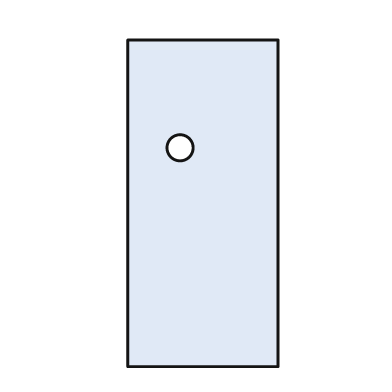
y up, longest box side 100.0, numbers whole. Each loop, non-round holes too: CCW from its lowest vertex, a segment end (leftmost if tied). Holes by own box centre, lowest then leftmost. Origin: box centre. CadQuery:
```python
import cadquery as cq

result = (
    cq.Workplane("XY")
    .moveTo(-23.0, -50.0)
    .lineTo(23.0, -50.0)
    .lineTo(23.0, 50.0)
    .lineTo(-23.0, 50.0)
    .close()
    .moveTo(-7.0, 17.0)
    .circle(4.0)
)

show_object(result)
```